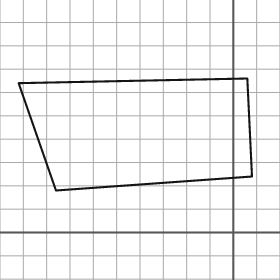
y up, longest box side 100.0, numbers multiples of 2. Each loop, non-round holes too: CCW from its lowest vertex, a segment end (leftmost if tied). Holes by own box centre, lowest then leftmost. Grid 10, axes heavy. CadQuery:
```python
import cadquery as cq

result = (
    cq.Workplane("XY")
    .moveTo(-76.0, 18.0)
    .lineTo(8.0, 24.0)
    .lineTo(6.0, 66.0)
    .lineTo(-92.0, 64.0)
    .close()
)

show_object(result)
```